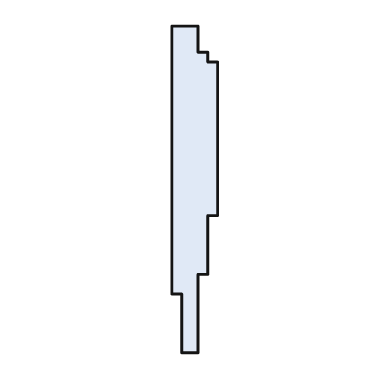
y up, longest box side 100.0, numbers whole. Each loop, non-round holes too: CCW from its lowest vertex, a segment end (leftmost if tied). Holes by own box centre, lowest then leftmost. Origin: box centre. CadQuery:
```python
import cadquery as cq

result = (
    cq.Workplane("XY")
    .moveTo(-4.0, -50.0)
    .lineTo(1.0, -50.0)
    .lineTo(1.0, -26.0)
    .lineTo(4.0, -26.0)
    .lineTo(4.0, -8.0)
    .lineTo(7.0, -8.0)
    .lineTo(7.0, 39.0)
    .lineTo(4.0, 39.0)
    .lineTo(4.0, 42.0)
    .lineTo(1.0, 42.0)
    .lineTo(1.0, 50.0)
    .lineTo(-7.0, 50.0)
    .lineTo(-7.0, -32.0)
    .lineTo(-4.0, -32.0)
    .close()
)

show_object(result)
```